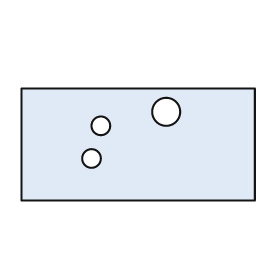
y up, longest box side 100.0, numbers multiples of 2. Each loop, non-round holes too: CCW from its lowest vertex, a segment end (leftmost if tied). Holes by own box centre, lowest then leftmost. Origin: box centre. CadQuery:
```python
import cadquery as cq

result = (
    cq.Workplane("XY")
    .moveTo(-50.0, -24.0)
    .lineTo(50.0, -24.0)
    .lineTo(50.0, 24.0)
    .lineTo(-50.0, 24.0)
    .close()
    .moveTo(-20.0, -6.0)
    .circle(4.0)
    .moveTo(-16.0, 8.0)
    .circle(4.0)
    .moveTo(12.0, 14.0)
    .circle(6.0)
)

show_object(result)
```